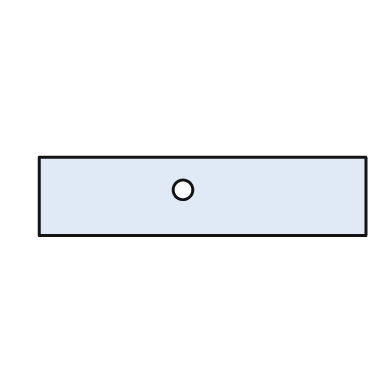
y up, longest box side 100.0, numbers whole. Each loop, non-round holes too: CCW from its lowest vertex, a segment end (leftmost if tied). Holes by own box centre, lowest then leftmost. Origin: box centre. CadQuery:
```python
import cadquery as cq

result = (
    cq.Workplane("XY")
    .moveTo(-50.0, -12.0)
    .lineTo(50.0, -12.0)
    .lineTo(50.0, 12.0)
    .lineTo(-50.0, 12.0)
    .close()
    .moveTo(-6.0, 2.0)
    .circle(3.0)
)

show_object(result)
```